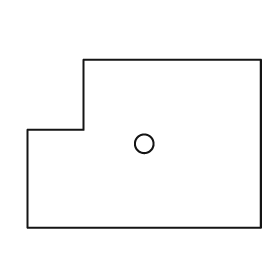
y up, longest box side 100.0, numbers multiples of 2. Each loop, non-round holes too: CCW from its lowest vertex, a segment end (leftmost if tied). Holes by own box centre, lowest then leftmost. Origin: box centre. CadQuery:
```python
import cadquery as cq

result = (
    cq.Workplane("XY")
    .moveTo(-50.0, -36.0)
    .lineTo(50.0, -36.0)
    .lineTo(50.0, 36.0)
    .lineTo(-26.0, 36.0)
    .lineTo(-26.0, 6.0)
    .lineTo(-50.0, 6.0)
    .close()
    .moveTo(0.0, 0.0)
    .circle(4.0)
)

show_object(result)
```